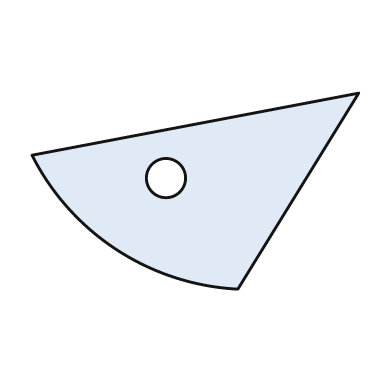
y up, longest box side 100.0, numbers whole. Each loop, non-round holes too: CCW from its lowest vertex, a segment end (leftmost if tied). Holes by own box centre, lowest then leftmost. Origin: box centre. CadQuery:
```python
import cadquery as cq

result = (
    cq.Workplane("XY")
    .moveTo(13.0, -30.0)
    .lineTo(50.0, 30.0)
    .lineTo(-50.0, 11.0)
    .threePointArc((-24.0, -18.0), (13.0, -30.0))
    .close()
    .moveTo(-9.0, 4.0)
    .circle(6.0)
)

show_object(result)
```